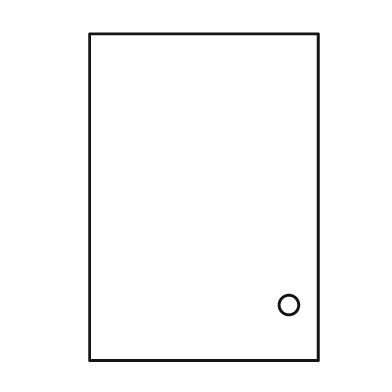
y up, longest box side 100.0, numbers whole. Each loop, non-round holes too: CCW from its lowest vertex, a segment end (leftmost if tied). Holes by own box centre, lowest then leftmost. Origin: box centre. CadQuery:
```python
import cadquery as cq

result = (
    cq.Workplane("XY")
    .moveTo(-35.0, -50.0)
    .lineTo(35.0, -50.0)
    .lineTo(35.0, 50.0)
    .lineTo(-35.0, 50.0)
    .close()
    .moveTo(26.0, -33.0)
    .circle(3.0)
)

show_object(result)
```